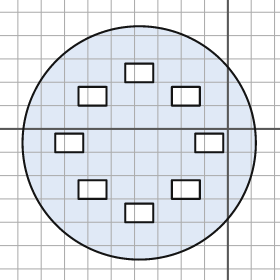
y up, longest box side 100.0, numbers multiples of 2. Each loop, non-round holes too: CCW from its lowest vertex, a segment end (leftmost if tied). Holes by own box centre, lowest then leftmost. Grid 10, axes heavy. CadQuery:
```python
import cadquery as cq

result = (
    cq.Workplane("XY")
    .moveTo(-38.0, -6.0)
    .circle(50.0)
    .moveTo(-44.0, -40.0)
    .lineTo(-32.0, -40.0)
    .lineTo(-32.0, -32.0)
    .lineTo(-44.0, -32.0)
    .close()
    .moveTo(-64.0, -30.0)
    .lineTo(-52.0, -30.0)
    .lineTo(-52.0, -22.0)
    .lineTo(-64.0, -22.0)
    .close()
    .moveTo(-24.0, -30.0)
    .lineTo(-12.0, -30.0)
    .lineTo(-12.0, -22.0)
    .lineTo(-24.0, -22.0)
    .close()
    .moveTo(-74.0, -10.0)
    .lineTo(-62.0, -10.0)
    .lineTo(-62.0, -2.0)
    .lineTo(-74.0, -2.0)
    .close()
    .moveTo(-14.0, -10.0)
    .lineTo(-2.0, -10.0)
    .lineTo(-2.0, -2.0)
    .lineTo(-14.0, -2.0)
    .close()
    .moveTo(-64.0, 10.0)
    .lineTo(-52.0, 10.0)
    .lineTo(-52.0, 18.0)
    .lineTo(-64.0, 18.0)
    .close()
    .moveTo(-24.0, 10.0)
    .lineTo(-12.0, 10.0)
    .lineTo(-12.0, 18.0)
    .lineTo(-24.0, 18.0)
    .close()
    .moveTo(-44.0, 20.0)
    .lineTo(-32.0, 20.0)
    .lineTo(-32.0, 28.0)
    .lineTo(-44.0, 28.0)
    .close()
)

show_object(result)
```